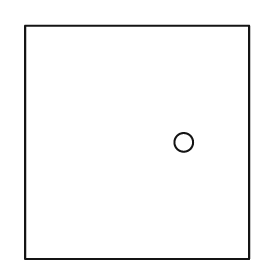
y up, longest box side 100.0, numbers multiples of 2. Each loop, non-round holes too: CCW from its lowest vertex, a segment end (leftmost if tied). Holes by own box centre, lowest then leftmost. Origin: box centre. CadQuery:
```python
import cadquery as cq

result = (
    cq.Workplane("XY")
    .moveTo(-48.0, -50.0)
    .lineTo(48.0, -50.0)
    .lineTo(48.0, 50.0)
    .lineTo(-48.0, 50.0)
    .close()
    .moveTo(20.0, 0.0)
    .circle(4.0)
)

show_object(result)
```